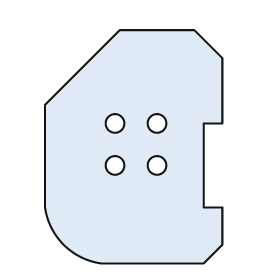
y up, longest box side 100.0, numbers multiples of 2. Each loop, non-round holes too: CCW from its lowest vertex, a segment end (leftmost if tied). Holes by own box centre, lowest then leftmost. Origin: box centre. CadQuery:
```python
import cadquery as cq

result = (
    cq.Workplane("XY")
    .moveTo(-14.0, -50.0)
    .lineTo(30.0, -50.0)
    .lineTo(38.0, -42.0)
    .lineTo(38.0, -26.0)
    .lineTo(30.0, -26.0)
    .lineTo(30.0, 10.0)
    .lineTo(38.0, 10.0)
    .lineTo(38.0, 38.0)
    .lineTo(26.0, 50.0)
    .lineTo(-6.0, 50.0)
    .lineTo(-38.0, 18.0)
    .lineTo(-38.0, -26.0)
    .threePointArc((-30.0, -42.0), (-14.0, -50.0))
    .close()
    .moveTo(-8.0, -8.0)
    .circle(4.0)
    .moveTo(10.0, -8.0)
    .circle(4.0)
    .moveTo(-8.0, 10.0)
    .circle(4.0)
    .moveTo(10.0, 10.0)
    .circle(4.0)
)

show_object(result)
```